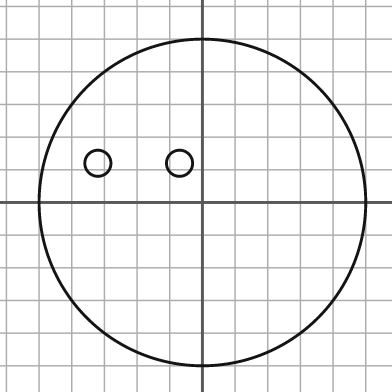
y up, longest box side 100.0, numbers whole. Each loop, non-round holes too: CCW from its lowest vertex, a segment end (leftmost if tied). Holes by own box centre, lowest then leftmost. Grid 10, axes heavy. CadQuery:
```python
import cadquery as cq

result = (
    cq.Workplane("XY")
    .moveTo(0.0, 0.0)
    .circle(50.0)
    .moveTo(-32.0, 12.0)
    .circle(4.0)
    .moveTo(-7.0, 12.0)
    .circle(4.0)
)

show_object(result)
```